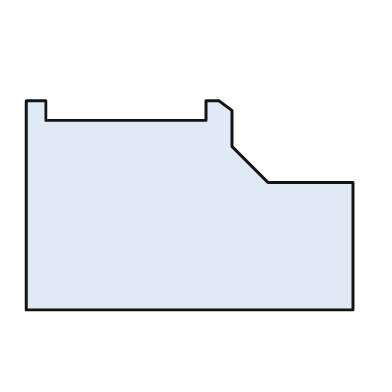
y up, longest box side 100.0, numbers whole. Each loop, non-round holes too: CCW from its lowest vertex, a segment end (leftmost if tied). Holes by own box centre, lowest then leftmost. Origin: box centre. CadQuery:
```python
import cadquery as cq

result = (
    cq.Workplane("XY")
    .moveTo(-50.0, -32.0)
    .lineTo(50.0, -32.0)
    .lineTo(50.0, 7.0)
    .lineTo(24.0, 7.0)
    .lineTo(13.0, 18.0)
    .lineTo(13.0, 29.0)
    .lineTo(9.0, 32.0)
    .lineTo(5.0, 32.0)
    .lineTo(5.0, 26.0)
    .lineTo(-44.0, 26.0)
    .lineTo(-44.0, 32.0)
    .lineTo(-50.0, 32.0)
    .close()
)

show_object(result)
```